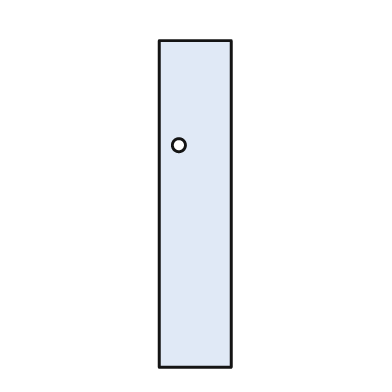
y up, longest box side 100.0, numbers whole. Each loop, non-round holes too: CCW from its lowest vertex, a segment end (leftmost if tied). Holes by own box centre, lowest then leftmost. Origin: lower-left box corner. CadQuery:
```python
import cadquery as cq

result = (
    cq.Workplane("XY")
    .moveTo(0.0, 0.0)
    .lineTo(22.0, 0.0)
    .lineTo(22.0, 100.0)
    .lineTo(0.0, 100.0)
    .close()
    .moveTo(6.0, 68.0)
    .circle(2.0)
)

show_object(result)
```